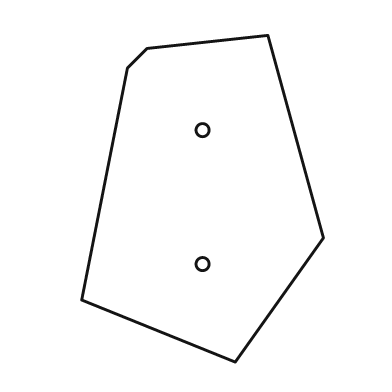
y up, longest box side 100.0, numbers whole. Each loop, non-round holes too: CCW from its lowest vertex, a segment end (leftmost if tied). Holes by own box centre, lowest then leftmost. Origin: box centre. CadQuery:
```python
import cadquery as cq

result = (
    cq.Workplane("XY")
    .moveTo(10.0, -50.0)
    .lineTo(37.0, -12.0)
    .lineTo(20.0, 50.0)
    .lineTo(-17.0, 46.0)
    .lineTo(-23.0, 40.0)
    .lineTo(-37.0, -31.0)
    .close()
    .moveTo(0.0, -20.0)
    .circle(2.0)
    .moveTo(0.0, 21.0)
    .circle(2.0)
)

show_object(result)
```